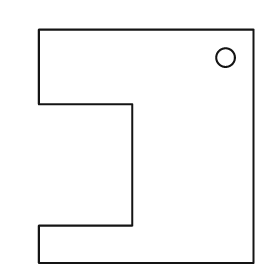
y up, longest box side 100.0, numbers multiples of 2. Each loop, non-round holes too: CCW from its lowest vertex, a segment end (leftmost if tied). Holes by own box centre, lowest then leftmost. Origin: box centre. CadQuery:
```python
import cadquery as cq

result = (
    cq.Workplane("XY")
    .moveTo(-46.0, -50.0)
    .lineTo(46.0, -50.0)
    .lineTo(46.0, 50.0)
    .lineTo(-46.0, 50.0)
    .lineTo(-46.0, 18.0)
    .lineTo(-6.0, 18.0)
    .lineTo(-6.0, -34.0)
    .lineTo(-46.0, -34.0)
    .close()
    .moveTo(34.0, 38.0)
    .circle(4.0)
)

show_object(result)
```